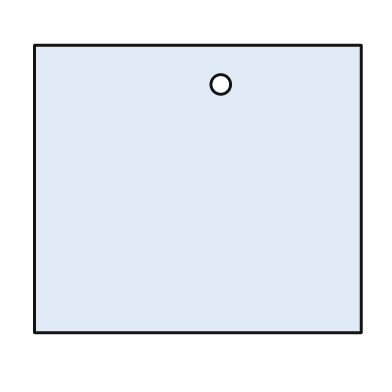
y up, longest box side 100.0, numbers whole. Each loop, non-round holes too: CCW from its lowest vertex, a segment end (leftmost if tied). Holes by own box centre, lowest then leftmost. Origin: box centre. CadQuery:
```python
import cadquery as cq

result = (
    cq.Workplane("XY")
    .moveTo(-50.0, -44.0)
    .lineTo(50.0, -44.0)
    .lineTo(50.0, 44.0)
    .lineTo(-50.0, 44.0)
    .close()
    .moveTo(7.0, 32.0)
    .circle(3.0)
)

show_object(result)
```